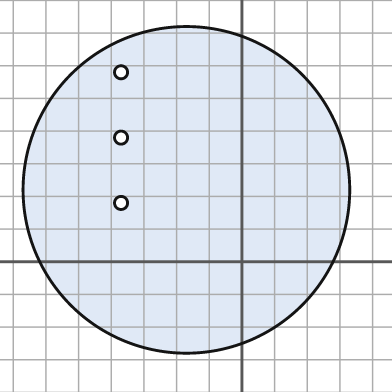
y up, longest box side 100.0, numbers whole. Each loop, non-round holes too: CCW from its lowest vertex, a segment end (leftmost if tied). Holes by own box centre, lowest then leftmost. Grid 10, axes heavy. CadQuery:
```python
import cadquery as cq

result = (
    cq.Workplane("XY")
    .moveTo(-17.0, 22.0)
    .circle(50.0)
    .moveTo(-37.0, 18.0)
    .circle(2.0)
    .moveTo(-37.0, 38.0)
    .circle(2.0)
    .moveTo(-37.0, 58.0)
    .circle(2.0)
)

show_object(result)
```